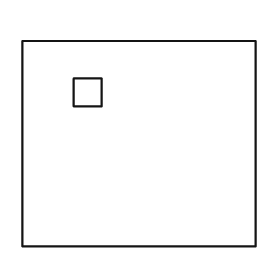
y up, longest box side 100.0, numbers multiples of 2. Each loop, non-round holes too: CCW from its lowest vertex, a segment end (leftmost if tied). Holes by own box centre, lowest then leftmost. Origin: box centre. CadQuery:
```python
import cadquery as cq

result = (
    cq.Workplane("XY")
    .moveTo(-50.0, -44.0)
    .lineTo(50.0, -44.0)
    .lineTo(50.0, 44.0)
    .lineTo(-50.0, 44.0)
    .close()
    .moveTo(-28.0, 16.0)
    .lineTo(-16.0, 16.0)
    .lineTo(-16.0, 28.0)
    .lineTo(-28.0, 28.0)
    .close()
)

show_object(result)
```